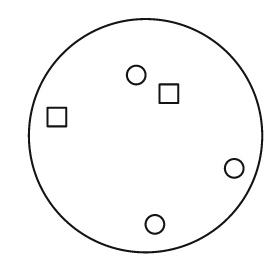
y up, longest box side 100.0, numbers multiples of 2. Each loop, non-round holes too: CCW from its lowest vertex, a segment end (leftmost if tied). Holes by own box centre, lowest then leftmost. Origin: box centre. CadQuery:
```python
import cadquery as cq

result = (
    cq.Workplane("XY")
    .moveTo(0.0, 0.0)
    .circle(50.0)
    .moveTo(4.0, -38.0)
    .circle(4.0)
    .moveTo(38.0, -14.0)
    .circle(4.0)
    .moveTo(-42.0, 4.0)
    .lineTo(-34.0, 4.0)
    .lineTo(-34.0, 12.0)
    .lineTo(-42.0, 12.0)
    .close()
    .moveTo(6.0, 14.0)
    .lineTo(14.0, 14.0)
    .lineTo(14.0, 22.0)
    .lineTo(6.0, 22.0)
    .close()
    .moveTo(-4.0, 26.0)
    .circle(4.0)
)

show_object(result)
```